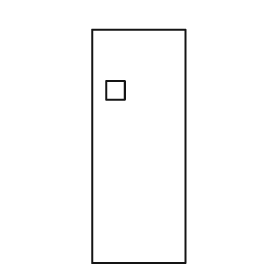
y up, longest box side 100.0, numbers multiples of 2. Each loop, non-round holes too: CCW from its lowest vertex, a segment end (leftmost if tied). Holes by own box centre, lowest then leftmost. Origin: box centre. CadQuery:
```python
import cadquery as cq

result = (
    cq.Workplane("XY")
    .moveTo(-20.0, -50.0)
    .lineTo(20.0, -50.0)
    .lineTo(20.0, 50.0)
    .lineTo(-20.0, 50.0)
    .close()
    .moveTo(-14.0, 20.0)
    .lineTo(-6.0, 20.0)
    .lineTo(-6.0, 28.0)
    .lineTo(-14.0, 28.0)
    .close()
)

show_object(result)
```